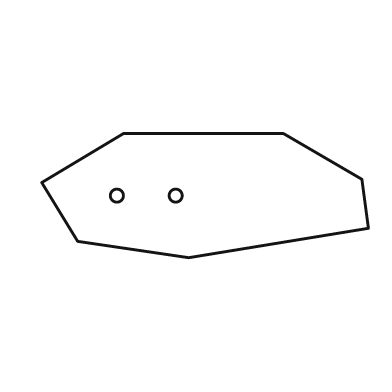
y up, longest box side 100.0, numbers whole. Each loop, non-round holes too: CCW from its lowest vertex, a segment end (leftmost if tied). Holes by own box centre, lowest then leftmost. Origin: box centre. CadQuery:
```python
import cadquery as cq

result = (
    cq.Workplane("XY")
    .moveTo(-5.0, -19.0)
    .lineTo(50.0, -10.0)
    .lineTo(48.0, 5.0)
    .lineTo(24.0, 19.0)
    .lineTo(-25.0, 19.0)
    .lineTo(-50.0, 4.0)
    .lineTo(-39.0, -14.0)
    .close()
    .moveTo(-27.0, 0.0)
    .circle(2.0)
    .moveTo(-9.0, 0.0)
    .circle(2.0)
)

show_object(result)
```